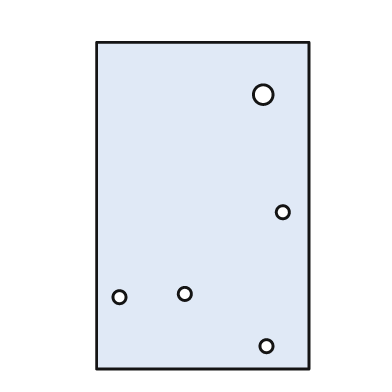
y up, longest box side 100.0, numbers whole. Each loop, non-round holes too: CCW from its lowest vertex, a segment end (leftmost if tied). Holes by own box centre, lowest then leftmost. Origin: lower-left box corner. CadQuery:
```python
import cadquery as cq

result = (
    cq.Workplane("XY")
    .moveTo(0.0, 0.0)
    .lineTo(65.0, 0.0)
    .lineTo(65.0, 100.0)
    .lineTo(0.0, 100.0)
    .close()
    .moveTo(52.0, 7.0)
    .circle(2.0)
    .moveTo(7.0, 22.0)
    .circle(2.0)
    .moveTo(27.0, 23.0)
    .circle(2.0)
    .moveTo(57.0, 48.0)
    .circle(2.0)
    .moveTo(51.0, 84.0)
    .circle(3.0)
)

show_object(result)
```